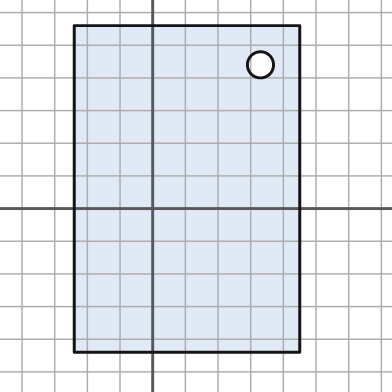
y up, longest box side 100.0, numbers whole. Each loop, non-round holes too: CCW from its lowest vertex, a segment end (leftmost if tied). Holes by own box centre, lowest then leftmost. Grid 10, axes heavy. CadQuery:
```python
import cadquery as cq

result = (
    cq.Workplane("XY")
    .moveTo(-24.0, -44.0)
    .lineTo(45.0, -44.0)
    .lineTo(45.0, 56.0)
    .lineTo(-24.0, 56.0)
    .close()
    .moveTo(33.0, 44.0)
    .circle(4.0)
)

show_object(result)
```